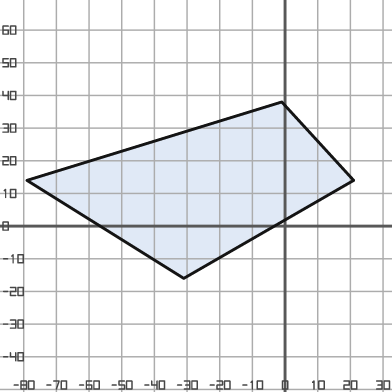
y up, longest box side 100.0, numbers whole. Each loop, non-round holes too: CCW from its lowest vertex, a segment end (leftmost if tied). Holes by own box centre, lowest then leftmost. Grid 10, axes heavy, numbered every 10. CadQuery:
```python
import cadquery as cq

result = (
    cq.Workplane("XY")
    .moveTo(-31.0, -16.0)
    .lineTo(21.0, 14.0)
    .lineTo(-1.0, 38.0)
    .lineTo(-79.0, 14.0)
    .close()
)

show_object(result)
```